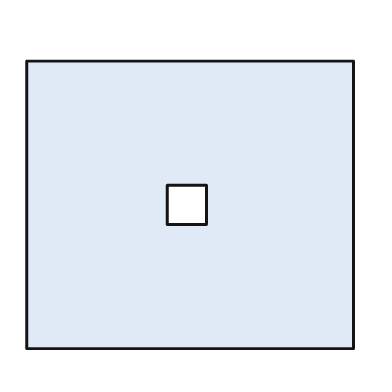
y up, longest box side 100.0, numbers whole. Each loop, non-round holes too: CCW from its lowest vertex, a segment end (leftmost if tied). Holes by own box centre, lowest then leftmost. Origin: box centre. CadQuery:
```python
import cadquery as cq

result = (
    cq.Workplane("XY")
    .moveTo(-50.0, -44.0)
    .lineTo(50.0, -44.0)
    .lineTo(50.0, 44.0)
    .lineTo(-50.0, 44.0)
    .close()
    .moveTo(-7.0, -6.0)
    .lineTo(5.0, -6.0)
    .lineTo(5.0, 6.0)
    .lineTo(-7.0, 6.0)
    .close()
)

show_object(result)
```